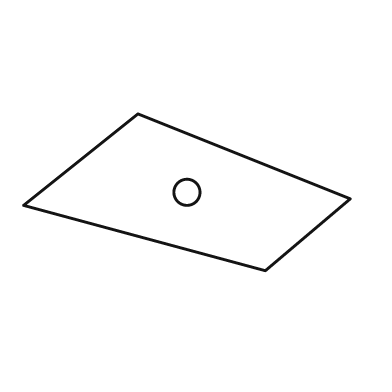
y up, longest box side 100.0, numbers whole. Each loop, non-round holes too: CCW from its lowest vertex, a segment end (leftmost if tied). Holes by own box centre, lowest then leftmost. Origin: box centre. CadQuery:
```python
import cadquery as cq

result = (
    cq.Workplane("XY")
    .moveTo(24.0, -24.0)
    .lineTo(50.0, -2.0)
    .lineTo(-15.0, 24.0)
    .lineTo(-50.0, -4.0)
    .close()
    .moveTo(0.0, 0.0)
    .circle(4.0)
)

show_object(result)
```